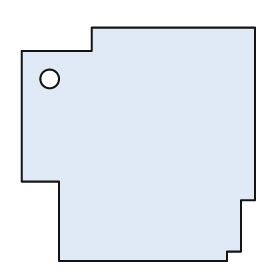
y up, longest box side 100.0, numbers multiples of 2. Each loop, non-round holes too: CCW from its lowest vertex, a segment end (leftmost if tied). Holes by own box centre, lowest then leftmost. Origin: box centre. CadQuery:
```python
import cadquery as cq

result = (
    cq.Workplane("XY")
    .moveTo(-34.0, -50.0)
    .lineTo(38.0, -50.0)
    .lineTo(38.0, -46.0)
    .lineTo(44.0, -46.0)
    .lineTo(44.0, -24.0)
    .lineTo(50.0, -24.0)
    .lineTo(50.0, 50.0)
    .lineTo(-20.0, 50.0)
    .lineTo(-20.0, 40.0)
    .lineTo(-50.0, 40.0)
    .lineTo(-50.0, -16.0)
    .lineTo(-34.0, -16.0)
    .close()
    .moveTo(-38.0, 28.0)
    .circle(4.0)
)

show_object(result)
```